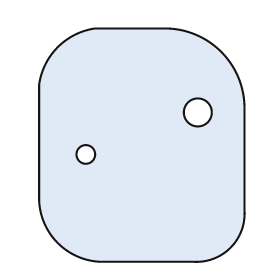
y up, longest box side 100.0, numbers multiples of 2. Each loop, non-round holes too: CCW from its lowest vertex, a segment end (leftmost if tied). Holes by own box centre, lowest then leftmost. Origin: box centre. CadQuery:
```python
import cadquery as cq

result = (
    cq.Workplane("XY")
    .moveTo(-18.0, -50.0)
    .lineTo(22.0, -50.0)
    .threePointArc((38.0, -44.0), (44.0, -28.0))
    .lineTo(44.0, 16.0)
    .threePointArc((34.0, 40.0), (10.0, 50.0))
    .lineTo(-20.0, 50.0)
    .threePointArc((-36.0, 42.0), (-44.0, 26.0))
    .lineTo(-44.0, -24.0)
    .threePointArc((-36.0, -42.0), (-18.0, -50.0))
    .close()
    .moveTo(-24.0, -4.0)
    .circle(4.0)
    .moveTo(24.0, 14.0)
    .circle(6.0)
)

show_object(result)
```